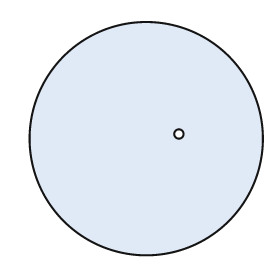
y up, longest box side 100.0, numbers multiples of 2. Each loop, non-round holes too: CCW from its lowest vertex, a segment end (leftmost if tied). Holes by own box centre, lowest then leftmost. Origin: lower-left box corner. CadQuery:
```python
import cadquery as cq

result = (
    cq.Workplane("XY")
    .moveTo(50.0, 50.0)
    .circle(50.0)
    .moveTo(64.0, 52.0)
    .circle(2.0)
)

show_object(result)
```